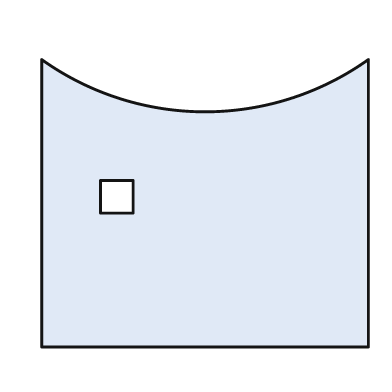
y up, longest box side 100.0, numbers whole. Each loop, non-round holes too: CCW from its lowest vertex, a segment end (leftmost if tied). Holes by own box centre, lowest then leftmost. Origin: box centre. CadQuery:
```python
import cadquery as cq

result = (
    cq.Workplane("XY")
    .moveTo(-50.0, -44.0)
    .lineTo(50.0, -44.0)
    .lineTo(50.0, 44.0)
    .threePointArc((0.0, 28.0), (-50.0, 44.0))
    .close()
    .moveTo(-32.0, -3.0)
    .lineTo(-22.0, -3.0)
    .lineTo(-22.0, 7.0)
    .lineTo(-32.0, 7.0)
    .close()
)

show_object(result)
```